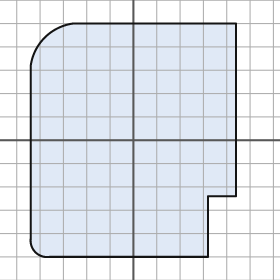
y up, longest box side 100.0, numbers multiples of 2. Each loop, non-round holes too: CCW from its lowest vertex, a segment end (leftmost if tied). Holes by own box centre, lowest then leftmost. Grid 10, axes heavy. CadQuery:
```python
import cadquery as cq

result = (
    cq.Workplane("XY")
    .moveTo(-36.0, -50.0)
    .lineTo(32.0, -50.0)
    .lineTo(32.0, -24.0)
    .lineTo(44.0, -24.0)
    .lineTo(44.0, 50.0)
    .lineTo(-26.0, 50.0)
    .threePointArc((-38.0, 44.0), (-44.0, 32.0))
    .lineTo(-44.0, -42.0)
    .threePointArc((-42.0, -48.0), (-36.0, -50.0))
    .close()
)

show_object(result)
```